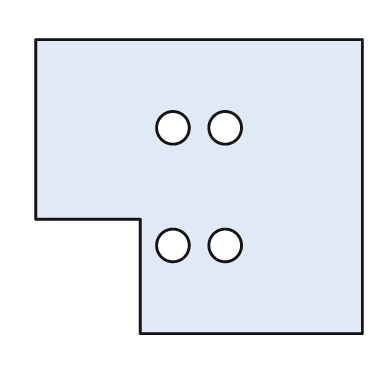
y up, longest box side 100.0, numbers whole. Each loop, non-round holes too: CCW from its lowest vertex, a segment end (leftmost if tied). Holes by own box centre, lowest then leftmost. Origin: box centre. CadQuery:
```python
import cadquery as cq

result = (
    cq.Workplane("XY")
    .moveTo(-18.0, -45.0)
    .lineTo(50.0, -45.0)
    .lineTo(50.0, 45.0)
    .lineTo(-50.0, 45.0)
    .lineTo(-50.0, -10.0)
    .lineTo(-18.0, -10.0)
    .close()
    .moveTo(-8.0, -18.0)
    .circle(5.0)
    .moveTo(8.0, -18.0)
    .circle(5.0)
    .moveTo(-8.0, 18.0)
    .circle(5.0)
    .moveTo(8.0, 18.0)
    .circle(5.0)
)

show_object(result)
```